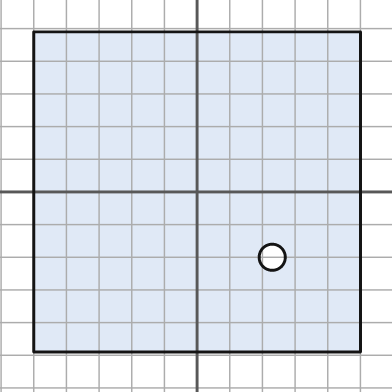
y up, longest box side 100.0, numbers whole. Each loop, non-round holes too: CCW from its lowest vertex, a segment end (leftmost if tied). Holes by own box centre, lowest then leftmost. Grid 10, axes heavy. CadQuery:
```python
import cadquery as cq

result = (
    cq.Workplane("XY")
    .moveTo(-50.0, -49.0)
    .lineTo(50.0, -49.0)
    .lineTo(50.0, 49.0)
    .lineTo(-50.0, 49.0)
    .close()
    .moveTo(23.0, -20.0)
    .circle(4.0)
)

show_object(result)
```